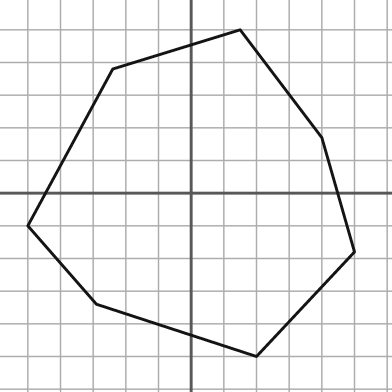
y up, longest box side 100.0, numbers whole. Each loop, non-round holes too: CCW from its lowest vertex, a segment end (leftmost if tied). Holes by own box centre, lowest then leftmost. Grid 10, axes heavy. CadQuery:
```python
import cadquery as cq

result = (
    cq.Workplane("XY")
    .moveTo(20.0, -50.0)
    .lineTo(50.0, -18.0)
    .lineTo(40.0, 17.0)
    .lineTo(15.0, 50.0)
    .lineTo(-24.0, 38.0)
    .lineTo(-50.0, -10.0)
    .lineTo(-29.0, -34.0)
    .close()
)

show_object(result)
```